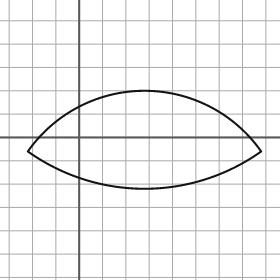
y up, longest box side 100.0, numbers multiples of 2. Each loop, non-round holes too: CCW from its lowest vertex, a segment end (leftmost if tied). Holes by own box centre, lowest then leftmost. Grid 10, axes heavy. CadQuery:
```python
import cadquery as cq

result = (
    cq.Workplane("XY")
    .moveTo(-22.0, -6.0)
    .threePointArc((28.0, -22.0), (78.0, -6.0))
    .threePointArc((28.0, 20.0), (-22.0, -6.0))
    .close()
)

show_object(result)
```